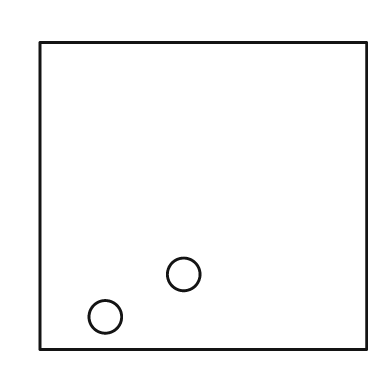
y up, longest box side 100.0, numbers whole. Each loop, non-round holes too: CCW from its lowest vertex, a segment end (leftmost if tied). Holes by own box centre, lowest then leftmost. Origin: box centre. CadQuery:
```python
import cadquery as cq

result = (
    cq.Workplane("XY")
    .moveTo(-50.0, -47.0)
    .lineTo(50.0, -47.0)
    .lineTo(50.0, 47.0)
    .lineTo(-50.0, 47.0)
    .close()
    .moveTo(-30.0, -37.0)
    .circle(5.0)
    .moveTo(-6.0, -24.0)
    .circle(5.0)
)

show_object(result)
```